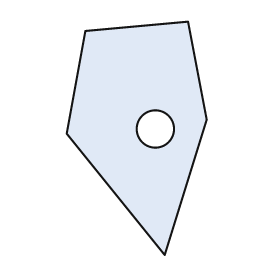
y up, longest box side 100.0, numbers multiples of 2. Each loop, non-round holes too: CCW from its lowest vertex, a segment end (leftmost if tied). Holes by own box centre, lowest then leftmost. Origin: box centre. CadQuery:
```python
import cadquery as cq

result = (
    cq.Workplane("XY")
    .moveTo(12.0, -50.0)
    .lineTo(30.0, 8.0)
    .lineTo(22.0, 50.0)
    .lineTo(-22.0, 46.0)
    .lineTo(-30.0, 2.0)
    .close()
    .moveTo(8.0, 4.0)
    .circle(8.0)
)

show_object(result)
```